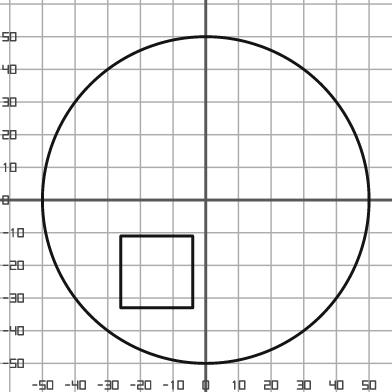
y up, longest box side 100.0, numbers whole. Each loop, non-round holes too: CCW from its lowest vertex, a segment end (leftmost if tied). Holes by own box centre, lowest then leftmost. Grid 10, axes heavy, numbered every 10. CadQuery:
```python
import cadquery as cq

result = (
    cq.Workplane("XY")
    .moveTo(0.0, 0.0)
    .circle(50.0)
    .moveTo(-26.0, -33.0)
    .lineTo(-4.0, -33.0)
    .lineTo(-4.0, -11.0)
    .lineTo(-26.0, -11.0)
    .close()
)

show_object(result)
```